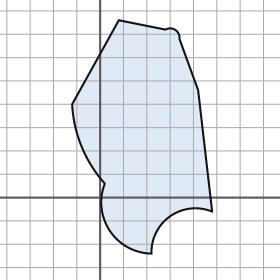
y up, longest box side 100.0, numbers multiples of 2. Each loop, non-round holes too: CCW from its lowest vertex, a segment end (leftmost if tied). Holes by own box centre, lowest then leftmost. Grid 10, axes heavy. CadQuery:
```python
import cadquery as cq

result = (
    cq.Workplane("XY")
    .moveTo(22.0, -24.0)
    .threePointArc((30.0, -8.0), (48.0, -6.0))
    .lineTo(42.0, 46.0)
    .lineTo(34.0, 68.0)
    .threePointArc((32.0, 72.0), (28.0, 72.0))
    .lineTo(8.0, 76.0)
    .lineTo(-12.0, 40.0)
    .threePointArc((-8.0, 22.0), (2.0, 6.0))
    .threePointArc((4.0, -14.0), (22.0, -24.0))
    .close()
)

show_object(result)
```